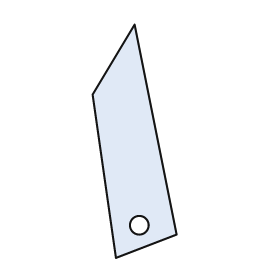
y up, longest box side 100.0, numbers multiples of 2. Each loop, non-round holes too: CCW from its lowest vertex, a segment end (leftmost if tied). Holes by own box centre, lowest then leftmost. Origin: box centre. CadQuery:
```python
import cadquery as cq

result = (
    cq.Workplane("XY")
    .moveTo(-8.0, -50.0)
    .lineTo(18.0, -40.0)
    .lineTo(0.0, 50.0)
    .lineTo(-18.0, 20.0)
    .close()
    .moveTo(2.0, -36.0)
    .circle(4.0)
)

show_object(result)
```